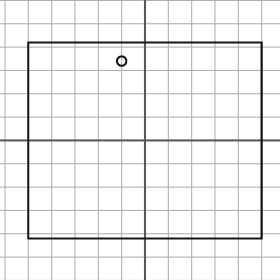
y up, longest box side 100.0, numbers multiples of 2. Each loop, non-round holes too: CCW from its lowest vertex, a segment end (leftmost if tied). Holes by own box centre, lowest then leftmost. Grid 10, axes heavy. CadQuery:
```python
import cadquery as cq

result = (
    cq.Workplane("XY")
    .moveTo(-50.0, -42.0)
    .lineTo(50.0, -42.0)
    .lineTo(50.0, 42.0)
    .lineTo(-50.0, 42.0)
    .close()
    .moveTo(-10.0, 34.0)
    .circle(2.0)
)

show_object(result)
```